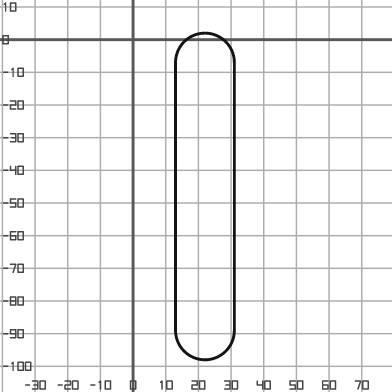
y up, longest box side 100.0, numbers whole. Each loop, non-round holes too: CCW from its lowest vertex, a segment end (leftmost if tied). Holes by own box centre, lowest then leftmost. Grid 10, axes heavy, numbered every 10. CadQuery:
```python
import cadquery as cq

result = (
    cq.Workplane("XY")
    .moveTo(13.0, -89.0)
    .threePointArc((22.0, -98.0), (31.0, -89.0))
    .lineTo(31.0, -7.0)
    .threePointArc((22.0, 2.0), (13.0, -7.0))
    .close()
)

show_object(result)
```